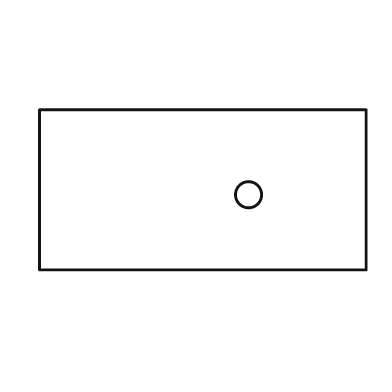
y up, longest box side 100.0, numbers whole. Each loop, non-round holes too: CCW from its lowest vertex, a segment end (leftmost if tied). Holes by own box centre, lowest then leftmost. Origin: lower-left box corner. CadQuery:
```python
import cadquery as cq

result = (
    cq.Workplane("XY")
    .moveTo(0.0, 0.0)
    .lineTo(100.0, 0.0)
    .lineTo(100.0, 49.0)
    .lineTo(0.0, 49.0)
    .close()
    .moveTo(64.0, 23.0)
    .circle(4.0)
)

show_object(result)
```